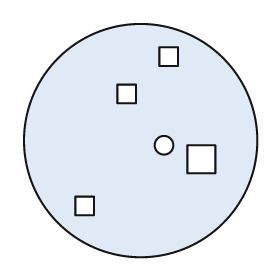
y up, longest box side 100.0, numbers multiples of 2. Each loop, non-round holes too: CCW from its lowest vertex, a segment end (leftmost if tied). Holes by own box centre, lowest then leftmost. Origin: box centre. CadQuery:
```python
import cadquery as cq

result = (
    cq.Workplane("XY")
    .moveTo(0.0, 0.0)
    .circle(50.0)
    .moveTo(-28.0, -32.0)
    .lineTo(-20.0, -32.0)
    .lineTo(-20.0, -24.0)
    .lineTo(-28.0, -24.0)
    .close()
    .moveTo(20.0, -14.0)
    .lineTo(32.0, -14.0)
    .lineTo(32.0, -2.0)
    .lineTo(20.0, -2.0)
    .close()
    .moveTo(10.0, -2.0)
    .circle(4.0)
    .moveTo(-10.0, 16.0)
    .lineTo(-2.0, 16.0)
    .lineTo(-2.0, 24.0)
    .lineTo(-10.0, 24.0)
    .close()
    .moveTo(8.0, 32.0)
    .lineTo(16.0, 32.0)
    .lineTo(16.0, 40.0)
    .lineTo(8.0, 40.0)
    .close()
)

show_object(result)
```